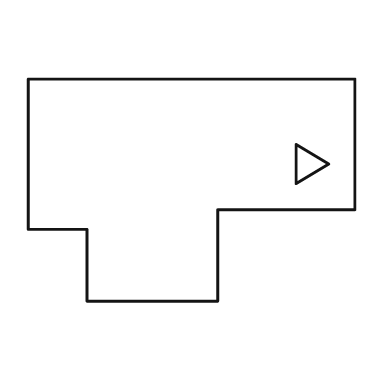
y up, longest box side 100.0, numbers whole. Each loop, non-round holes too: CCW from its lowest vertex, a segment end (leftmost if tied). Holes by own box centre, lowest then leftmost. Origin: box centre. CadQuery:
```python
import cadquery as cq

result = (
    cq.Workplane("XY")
    .moveTo(-32.0, -34.0)
    .lineTo(8.0, -34.0)
    .lineTo(8.0, -6.0)
    .lineTo(50.0, -6.0)
    .lineTo(50.0, 34.0)
    .lineTo(-50.0, 34.0)
    .lineTo(-50.0, -12.0)
    .lineTo(-32.0, -12.0)
    .close()
    .moveTo(32.0, 2.0)
    .lineTo(42.0, 8.0)
    .lineTo(32.0, 14.0)
    .close()
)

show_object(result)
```